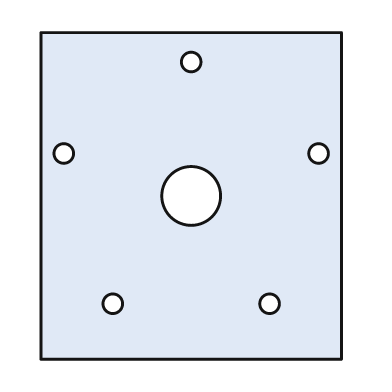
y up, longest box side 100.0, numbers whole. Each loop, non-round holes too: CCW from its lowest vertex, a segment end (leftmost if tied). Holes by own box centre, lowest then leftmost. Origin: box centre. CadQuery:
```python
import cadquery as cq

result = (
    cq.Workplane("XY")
    .moveTo(-46.0, -50.0)
    .lineTo(46.0, -50.0)
    .lineTo(46.0, 50.0)
    .lineTo(-46.0, 50.0)
    .close()
    .moveTo(-24.0, -33.0)
    .circle(3.0)
    .moveTo(24.0, -33.0)
    .circle(3.0)
    .moveTo(0.0, 0.0)
    .circle(9.0)
    .moveTo(-39.0, 13.0)
    .circle(3.0)
    .moveTo(39.0, 13.0)
    .circle(3.0)
    .moveTo(0.0, 41.0)
    .circle(3.0)
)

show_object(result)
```